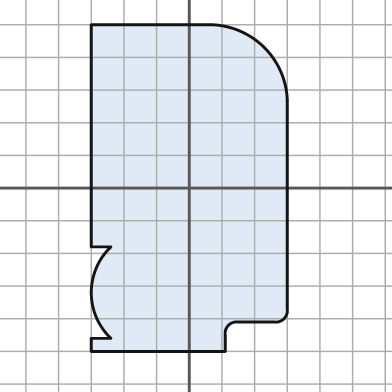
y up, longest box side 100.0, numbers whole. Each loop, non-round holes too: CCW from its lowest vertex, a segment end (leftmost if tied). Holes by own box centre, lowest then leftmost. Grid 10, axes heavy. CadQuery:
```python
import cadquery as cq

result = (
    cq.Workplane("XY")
    .moveTo(-30.0, -50.0)
    .lineTo(11.0, -50.0)
    .lineTo(11.0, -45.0)
    .threePointArc((12.0, -42.0), (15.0, -41.0))
    .lineTo(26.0, -41.0)
    .threePointArc((29.0, -40.0), (30.0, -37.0))
    .lineTo(30.0, 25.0)
    .threePointArc((23.0, 43.0), (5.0, 50.0))
    .lineTo(-30.0, 50.0)
    .lineTo(-30.0, -18.0)
    .lineTo(-24.0, -18.0)
    .threePointArc((-30.0, -32.0), (-24.0, -46.0))
    .lineTo(-30.0, -46.0)
    .close()
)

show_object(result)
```